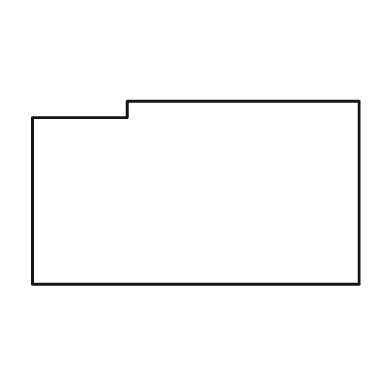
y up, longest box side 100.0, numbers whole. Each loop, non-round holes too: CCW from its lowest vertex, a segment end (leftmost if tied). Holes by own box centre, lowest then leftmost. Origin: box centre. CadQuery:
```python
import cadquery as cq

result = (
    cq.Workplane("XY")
    .moveTo(-50.0, -28.0)
    .lineTo(50.0, -28.0)
    .lineTo(50.0, 28.0)
    .lineTo(-21.0, 28.0)
    .lineTo(-21.0, 23.0)
    .lineTo(-50.0, 23.0)
    .close()
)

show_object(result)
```